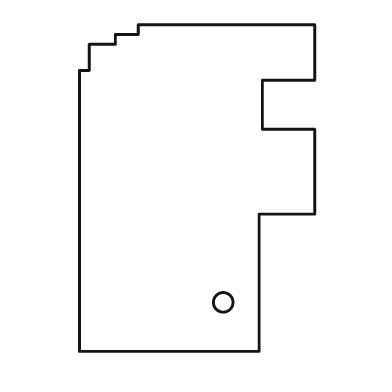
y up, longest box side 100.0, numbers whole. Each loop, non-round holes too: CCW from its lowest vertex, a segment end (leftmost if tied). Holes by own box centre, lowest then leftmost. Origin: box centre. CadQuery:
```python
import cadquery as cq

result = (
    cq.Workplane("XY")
    .moveTo(-36.0, -50.0)
    .lineTo(19.0, -50.0)
    .lineTo(19.0, -8.0)
    .lineTo(36.0, -8.0)
    .lineTo(36.0, 18.0)
    .lineTo(20.0, 18.0)
    .lineTo(20.0, 33.0)
    .lineTo(36.0, 33.0)
    .lineTo(36.0, 50.0)
    .lineTo(-18.0, 50.0)
    .lineTo(-18.0, 47.0)
    .lineTo(-25.0, 47.0)
    .lineTo(-25.0, 44.0)
    .lineTo(-33.0, 44.0)
    .lineTo(-33.0, 36.0)
    .lineTo(-36.0, 36.0)
    .close()
    .moveTo(8.0, -35.0)
    .circle(3.0)
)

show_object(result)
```